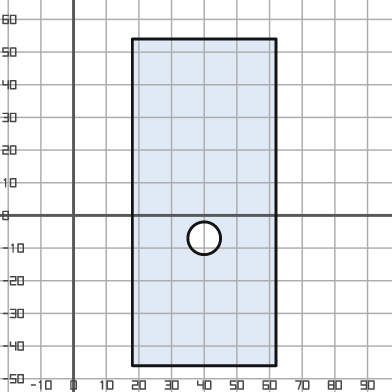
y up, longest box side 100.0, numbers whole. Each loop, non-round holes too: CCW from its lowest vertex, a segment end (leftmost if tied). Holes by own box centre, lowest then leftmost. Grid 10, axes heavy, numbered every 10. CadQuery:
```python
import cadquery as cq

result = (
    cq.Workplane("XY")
    .moveTo(18.0, -46.0)
    .lineTo(62.0, -46.0)
    .lineTo(62.0, 54.0)
    .lineTo(18.0, 54.0)
    .close()
    .moveTo(40.0, -7.0)
    .circle(5.0)
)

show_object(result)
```